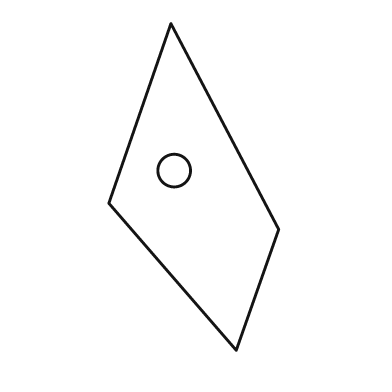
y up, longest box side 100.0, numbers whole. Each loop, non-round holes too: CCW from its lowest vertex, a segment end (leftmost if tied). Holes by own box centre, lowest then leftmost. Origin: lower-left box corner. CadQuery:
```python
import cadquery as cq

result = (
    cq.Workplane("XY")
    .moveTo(39.0, 0.0)
    .lineTo(52.0, 37.0)
    .lineTo(19.0, 100.0)
    .lineTo(0.0, 45.0)
    .close()
    .moveTo(20.0, 55.0)
    .circle(5.0)
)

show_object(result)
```